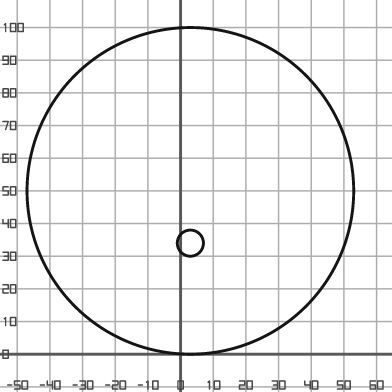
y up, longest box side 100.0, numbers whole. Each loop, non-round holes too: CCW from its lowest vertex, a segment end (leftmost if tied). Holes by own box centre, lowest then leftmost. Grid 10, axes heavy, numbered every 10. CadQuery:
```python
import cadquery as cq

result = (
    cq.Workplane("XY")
    .moveTo(3.0, 50.0)
    .circle(50.0)
    .moveTo(3.0, 34.0)
    .circle(4.0)
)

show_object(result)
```